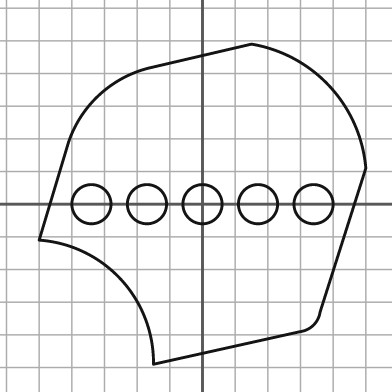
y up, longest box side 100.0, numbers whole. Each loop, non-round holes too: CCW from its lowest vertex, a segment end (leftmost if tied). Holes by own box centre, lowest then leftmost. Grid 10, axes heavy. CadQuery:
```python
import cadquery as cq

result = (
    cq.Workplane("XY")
    .moveTo(-15.0, -49.0)
    .lineTo(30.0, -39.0)
    .threePointArc((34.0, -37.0), (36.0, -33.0))
    .lineTo(50.0, 11.0)
    .threePointArc((39.0, 36.0), (15.0, 49.0))
    .lineTo(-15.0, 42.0)
    .threePointArc((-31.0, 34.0), (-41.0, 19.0))
    .lineTo(-50.0, -11.0)
    .threePointArc((-25.0, -23.0), (-15.0, -49.0))
    .close()
    .moveTo(-34.0, 0.0)
    .circle(6.0)
    .moveTo(-17.0, 0.0)
    .circle(6.0)
    .moveTo(0.0, 0.0)
    .circle(6.0)
    .moveTo(17.0, 0.0)
    .circle(6.0)
    .moveTo(34.0, 0.0)
    .circle(6.0)
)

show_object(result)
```